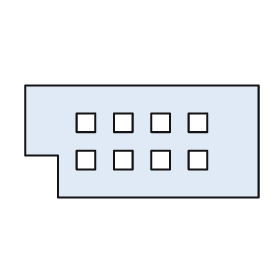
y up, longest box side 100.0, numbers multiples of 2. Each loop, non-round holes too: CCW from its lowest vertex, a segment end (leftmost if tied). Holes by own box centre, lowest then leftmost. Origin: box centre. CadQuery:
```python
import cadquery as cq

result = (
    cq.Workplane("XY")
    .moveTo(-36.0, -24.0)
    .lineTo(50.0, -24.0)
    .lineTo(50.0, 24.0)
    .lineTo(-50.0, 24.0)
    .lineTo(-50.0, -6.0)
    .lineTo(-36.0, -6.0)
    .close()
    .moveTo(-28.0, -12.0)
    .lineTo(-20.0, -12.0)
    .lineTo(-20.0, -4.0)
    .lineTo(-28.0, -4.0)
    .close()
    .moveTo(-12.0, -12.0)
    .lineTo(-4.0, -12.0)
    .lineTo(-4.0, -4.0)
    .lineTo(-12.0, -4.0)
    .close()
    .moveTo(4.0, -12.0)
    .lineTo(12.0, -12.0)
    .lineTo(12.0, -4.0)
    .lineTo(4.0, -4.0)
    .close()
    .moveTo(20.0, -12.0)
    .lineTo(28.0, -12.0)
    .lineTo(28.0, -4.0)
    .lineTo(20.0, -4.0)
    .close()
    .moveTo(-28.0, 4.0)
    .lineTo(-20.0, 4.0)
    .lineTo(-20.0, 12.0)
    .lineTo(-28.0, 12.0)
    .close()
    .moveTo(-12.0, 4.0)
    .lineTo(-4.0, 4.0)
    .lineTo(-4.0, 12.0)
    .lineTo(-12.0, 12.0)
    .close()
    .moveTo(4.0, 4.0)
    .lineTo(12.0, 4.0)
    .lineTo(12.0, 12.0)
    .lineTo(4.0, 12.0)
    .close()
    .moveTo(20.0, 4.0)
    .lineTo(28.0, 4.0)
    .lineTo(28.0, 12.0)
    .lineTo(20.0, 12.0)
    .close()
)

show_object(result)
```